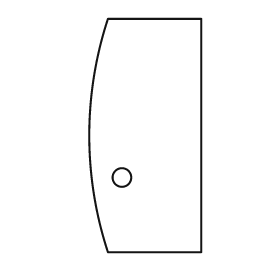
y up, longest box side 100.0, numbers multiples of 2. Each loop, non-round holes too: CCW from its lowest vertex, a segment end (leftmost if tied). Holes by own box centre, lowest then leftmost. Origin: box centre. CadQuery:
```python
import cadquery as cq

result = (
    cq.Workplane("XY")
    .moveTo(-16.0, -50.0)
    .lineTo(24.0, -50.0)
    .lineTo(24.0, 50.0)
    .lineTo(-16.0, 50.0)
    .threePointArc((-24.0, 0.0), (-16.0, -50.0))
    .close()
    .moveTo(-10.0, -18.0)
    .circle(4.0)
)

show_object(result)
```